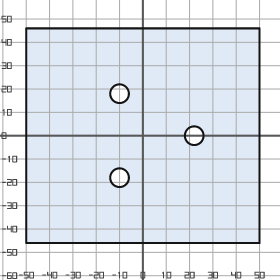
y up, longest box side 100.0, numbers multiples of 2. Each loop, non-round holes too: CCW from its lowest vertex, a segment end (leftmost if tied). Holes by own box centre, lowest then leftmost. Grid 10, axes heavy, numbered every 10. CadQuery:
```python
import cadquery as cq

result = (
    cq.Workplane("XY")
    .moveTo(-50.0, -46.0)
    .lineTo(50.0, -46.0)
    .lineTo(50.0, 46.0)
    .lineTo(-50.0, 46.0)
    .close()
    .moveTo(-10.0, -18.0)
    .circle(4.0)
    .moveTo(22.0, 0.0)
    .circle(4.0)
    .moveTo(-10.0, 18.0)
    .circle(4.0)
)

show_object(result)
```